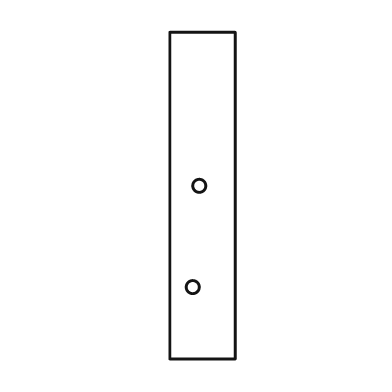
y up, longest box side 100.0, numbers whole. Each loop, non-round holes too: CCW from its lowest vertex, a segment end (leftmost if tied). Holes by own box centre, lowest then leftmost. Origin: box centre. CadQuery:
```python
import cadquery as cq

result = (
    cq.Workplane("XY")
    .moveTo(-10.0, -50.0)
    .lineTo(10.0, -50.0)
    .lineTo(10.0, 50.0)
    .lineTo(-10.0, 50.0)
    .close()
    .moveTo(-3.0, -28.0)
    .circle(2.0)
    .moveTo(-1.0, 3.0)
    .circle(2.0)
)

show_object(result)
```